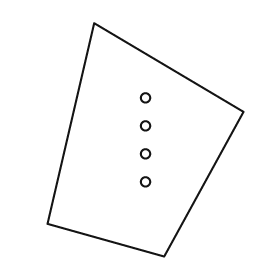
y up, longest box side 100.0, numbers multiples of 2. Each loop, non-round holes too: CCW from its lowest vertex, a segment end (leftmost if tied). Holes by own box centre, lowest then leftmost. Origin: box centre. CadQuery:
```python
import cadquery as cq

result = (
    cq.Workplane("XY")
    .moveTo(8.0, -50.0)
    .lineTo(42.0, 12.0)
    .lineTo(-22.0, 50.0)
    .lineTo(-42.0, -36.0)
    .close()
    .moveTo(0.0, -18.0)
    .circle(2.0)
    .moveTo(0.0, -6.0)
    .circle(2.0)
    .moveTo(0.0, 6.0)
    .circle(2.0)
    .moveTo(0.0, 18.0)
    .circle(2.0)
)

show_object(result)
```